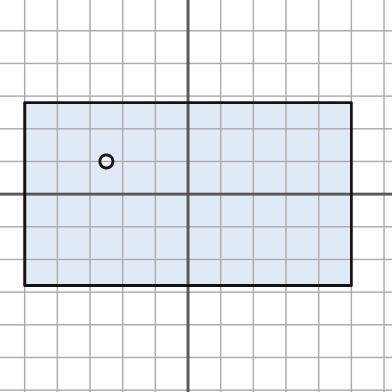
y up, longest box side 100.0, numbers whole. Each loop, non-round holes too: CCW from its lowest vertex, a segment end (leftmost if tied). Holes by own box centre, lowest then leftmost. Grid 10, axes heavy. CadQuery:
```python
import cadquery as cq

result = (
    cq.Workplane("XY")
    .moveTo(-50.0, -28.0)
    .lineTo(50.0, -28.0)
    .lineTo(50.0, 28.0)
    .lineTo(-50.0, 28.0)
    .close()
    .moveTo(-25.0, 10.0)
    .circle(2.0)
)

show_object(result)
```